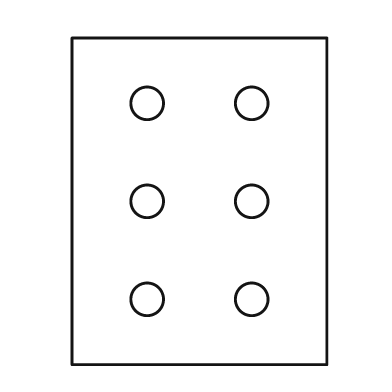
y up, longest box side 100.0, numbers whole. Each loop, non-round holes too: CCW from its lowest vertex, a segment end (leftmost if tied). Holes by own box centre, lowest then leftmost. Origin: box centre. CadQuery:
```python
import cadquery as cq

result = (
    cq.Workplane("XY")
    .moveTo(-39.0, -50.0)
    .lineTo(39.0, -50.0)
    .lineTo(39.0, 50.0)
    .lineTo(-39.0, 50.0)
    .close()
    .moveTo(-16.0, -30.0)
    .circle(5.0)
    .moveTo(16.0, -30.0)
    .circle(5.0)
    .moveTo(-16.0, 0.0)
    .circle(5.0)
    .moveTo(16.0, 0.0)
    .circle(5.0)
    .moveTo(-16.0, 30.0)
    .circle(5.0)
    .moveTo(16.0, 30.0)
    .circle(5.0)
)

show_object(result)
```